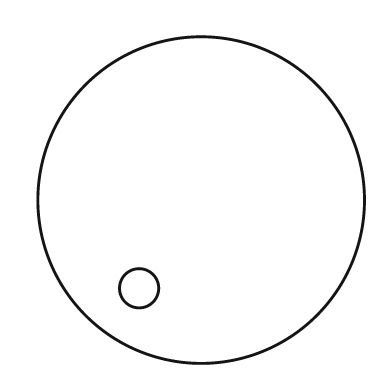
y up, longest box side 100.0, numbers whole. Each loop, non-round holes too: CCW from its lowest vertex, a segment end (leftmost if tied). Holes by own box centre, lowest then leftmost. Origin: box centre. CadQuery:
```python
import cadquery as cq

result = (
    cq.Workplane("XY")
    .moveTo(0.0, 0.0)
    .circle(50.0)
    .moveTo(-19.0, -27.0)
    .circle(6.0)
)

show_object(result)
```